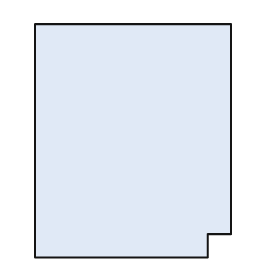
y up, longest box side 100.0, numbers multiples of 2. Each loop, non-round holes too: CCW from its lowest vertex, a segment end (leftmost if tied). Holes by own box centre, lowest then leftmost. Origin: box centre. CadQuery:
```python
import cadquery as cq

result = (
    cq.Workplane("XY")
    .moveTo(-42.0, -50.0)
    .lineTo(32.0, -50.0)
    .lineTo(32.0, -40.0)
    .lineTo(42.0, -40.0)
    .lineTo(42.0, 50.0)
    .lineTo(-42.0, 50.0)
    .close()
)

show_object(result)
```